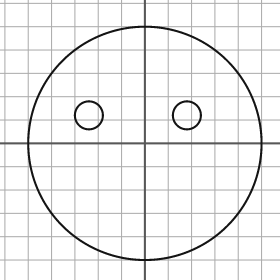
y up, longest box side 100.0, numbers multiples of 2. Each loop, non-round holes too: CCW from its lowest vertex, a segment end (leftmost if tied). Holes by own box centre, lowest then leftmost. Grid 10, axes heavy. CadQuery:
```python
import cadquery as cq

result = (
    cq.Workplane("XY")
    .moveTo(0.0, 0.0)
    .circle(50.0)
    .moveTo(-24.0, 12.0)
    .circle(6.0)
    .moveTo(18.0, 12.0)
    .circle(6.0)
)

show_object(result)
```